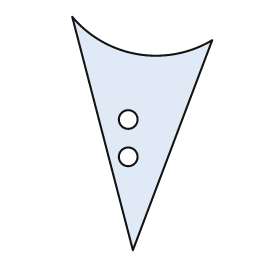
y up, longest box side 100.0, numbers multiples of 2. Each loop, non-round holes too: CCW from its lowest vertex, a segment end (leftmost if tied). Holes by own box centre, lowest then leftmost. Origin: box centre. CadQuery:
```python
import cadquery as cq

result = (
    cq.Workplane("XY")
    .moveTo(-4.0, -50.0)
    .lineTo(30.0, 40.0)
    .threePointArc((-2.0, 34.0), (-30.0, 50.0))
    .close()
    .moveTo(-6.0, -10.0)
    .circle(4.0)
    .moveTo(-6.0, 6.0)
    .circle(4.0)
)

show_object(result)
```